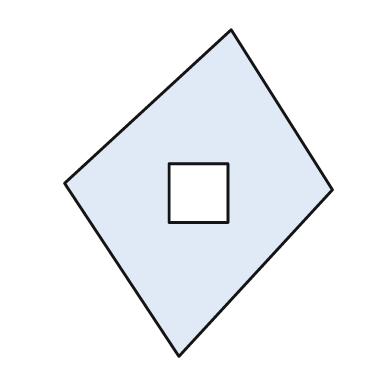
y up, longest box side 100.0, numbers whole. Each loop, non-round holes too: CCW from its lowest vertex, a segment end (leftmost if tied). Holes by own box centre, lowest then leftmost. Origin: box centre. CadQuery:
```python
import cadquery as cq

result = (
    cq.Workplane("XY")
    .moveTo(-6.0, -50.0)
    .lineTo(41.0, 1.0)
    .lineTo(10.0, 50.0)
    .lineTo(-41.0, 3.0)
    .close()
    .moveTo(-9.0, -9.0)
    .lineTo(9.0, -9.0)
    .lineTo(9.0, 9.0)
    .lineTo(-9.0, 9.0)
    .close()
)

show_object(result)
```